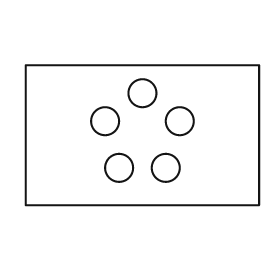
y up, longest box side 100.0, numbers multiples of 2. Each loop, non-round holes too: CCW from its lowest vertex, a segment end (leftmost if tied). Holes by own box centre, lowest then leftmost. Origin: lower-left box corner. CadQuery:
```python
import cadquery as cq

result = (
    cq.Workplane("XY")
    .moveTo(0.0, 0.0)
    .lineTo(100.0, 0.0)
    .lineTo(100.0, 60.0)
    .lineTo(0.0, 60.0)
    .close()
    .moveTo(40.0, 16.0)
    .circle(6.0)
    .moveTo(60.0, 16.0)
    .circle(6.0)
    .moveTo(34.0, 36.0)
    .circle(6.0)
    .moveTo(66.0, 36.0)
    .circle(6.0)
    .moveTo(50.0, 48.0)
    .circle(6.0)
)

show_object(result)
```